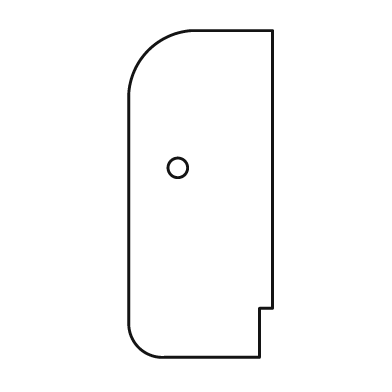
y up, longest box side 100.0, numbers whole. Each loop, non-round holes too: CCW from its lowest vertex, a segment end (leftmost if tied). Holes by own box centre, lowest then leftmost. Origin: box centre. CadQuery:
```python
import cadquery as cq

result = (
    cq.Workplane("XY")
    .moveTo(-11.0, -50.0)
    .lineTo(18.0, -50.0)
    .lineTo(18.0, -35.0)
    .lineTo(22.0, -35.0)
    .lineTo(22.0, 50.0)
    .lineTo(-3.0, 50.0)
    .threePointArc((-16.0, 44.0), (-22.0, 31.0))
    .lineTo(-22.0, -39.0)
    .threePointArc((-19.0, -47.0), (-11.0, -50.0))
    .close()
    .moveTo(-7.0, 8.0)
    .circle(3.0)
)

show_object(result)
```